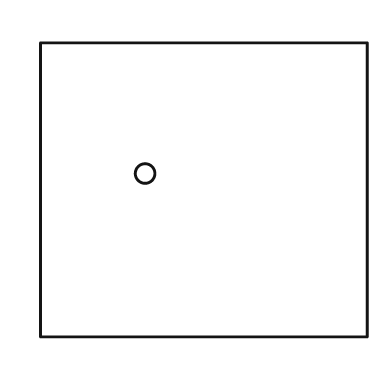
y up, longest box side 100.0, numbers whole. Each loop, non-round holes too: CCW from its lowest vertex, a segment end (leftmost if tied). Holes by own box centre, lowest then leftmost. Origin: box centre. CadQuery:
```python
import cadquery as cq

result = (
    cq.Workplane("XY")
    .moveTo(-50.0, -45.0)
    .lineTo(50.0, -45.0)
    .lineTo(50.0, 45.0)
    .lineTo(-50.0, 45.0)
    .close()
    .moveTo(-18.0, 5.0)
    .circle(3.0)
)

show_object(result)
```